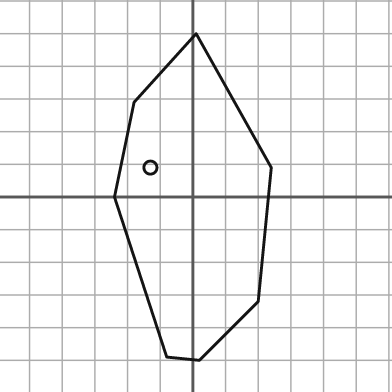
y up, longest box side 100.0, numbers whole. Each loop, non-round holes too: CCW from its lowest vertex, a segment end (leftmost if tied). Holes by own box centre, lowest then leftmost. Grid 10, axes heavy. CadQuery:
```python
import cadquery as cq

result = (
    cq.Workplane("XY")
    .moveTo(2.0, -50.0)
    .lineTo(20.0, -32.0)
    .lineTo(24.0, 9.0)
    .lineTo(1.0, 50.0)
    .lineTo(-18.0, 29.0)
    .lineTo(-24.0, 0.0)
    .lineTo(-8.0, -49.0)
    .close()
    .moveTo(-13.0, 9.0)
    .circle(2.0)
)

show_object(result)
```